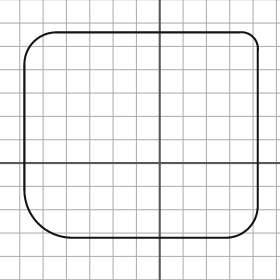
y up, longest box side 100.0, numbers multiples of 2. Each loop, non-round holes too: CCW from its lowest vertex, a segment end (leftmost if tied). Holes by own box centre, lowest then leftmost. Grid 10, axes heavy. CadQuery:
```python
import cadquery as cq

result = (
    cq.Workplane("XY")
    .moveTo(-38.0, -32.0)
    .lineTo(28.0, -32.0)
    .threePointArc((38.0, -28.0), (42.0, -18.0))
    .lineTo(42.0, 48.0)
    .threePointArc((40.0, 54.0), (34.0, 56.0))
    .lineTo(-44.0, 56.0)
    .threePointArc((-54.0, 52.0), (-58.0, 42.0))
    .lineTo(-58.0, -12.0)
    .threePointArc((-52.0, -26.0), (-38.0, -32.0))
    .close()
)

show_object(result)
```